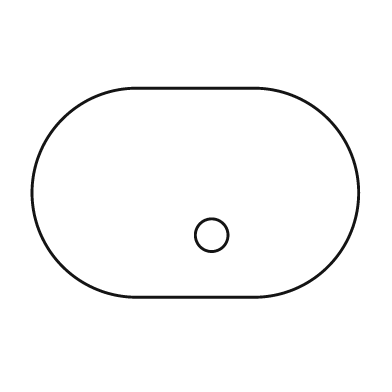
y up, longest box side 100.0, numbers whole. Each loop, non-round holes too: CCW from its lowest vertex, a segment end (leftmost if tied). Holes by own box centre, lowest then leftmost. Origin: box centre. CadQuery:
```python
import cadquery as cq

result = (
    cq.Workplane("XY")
    .moveTo(-18.0, -32.0)
    .lineTo(18.0, -32.0)
    .threePointArc((50.0, 0.0), (18.0, 32.0))
    .lineTo(-18.0, 32.0)
    .threePointArc((-50.0, 0.0), (-18.0, -32.0))
    .close()
    .moveTo(5.0, -13.0)
    .circle(5.0)
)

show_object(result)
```